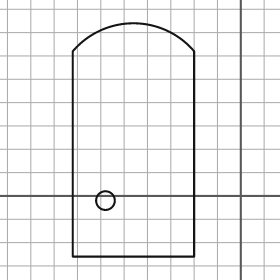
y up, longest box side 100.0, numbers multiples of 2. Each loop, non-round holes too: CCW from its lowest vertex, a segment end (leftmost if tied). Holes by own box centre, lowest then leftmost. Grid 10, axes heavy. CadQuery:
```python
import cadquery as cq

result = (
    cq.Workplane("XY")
    .moveTo(-72.0, -26.0)
    .lineTo(-20.0, -26.0)
    .lineTo(-20.0, 62.0)
    .threePointArc((-46.0, 74.0), (-72.0, 62.0))
    .close()
    .moveTo(-58.0, -2.0)
    .circle(4.0)
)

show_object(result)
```